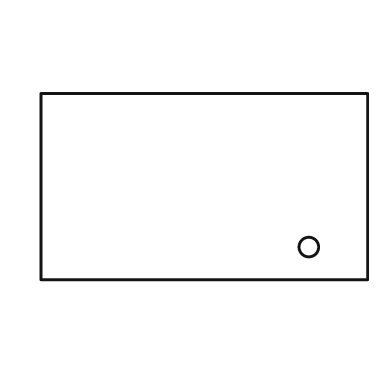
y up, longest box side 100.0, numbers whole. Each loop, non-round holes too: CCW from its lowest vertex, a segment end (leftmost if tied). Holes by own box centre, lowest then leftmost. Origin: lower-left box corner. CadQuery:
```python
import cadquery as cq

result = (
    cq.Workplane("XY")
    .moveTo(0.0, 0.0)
    .lineTo(100.0, 0.0)
    .lineTo(100.0, 57.0)
    .lineTo(0.0, 57.0)
    .close()
    .moveTo(82.0, 10.0)
    .circle(3.0)
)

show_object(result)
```